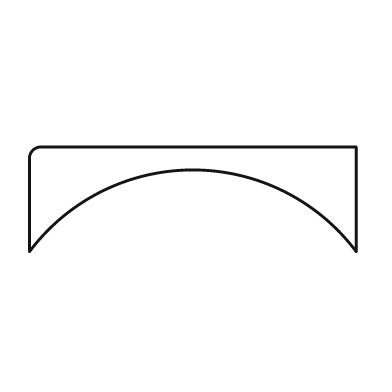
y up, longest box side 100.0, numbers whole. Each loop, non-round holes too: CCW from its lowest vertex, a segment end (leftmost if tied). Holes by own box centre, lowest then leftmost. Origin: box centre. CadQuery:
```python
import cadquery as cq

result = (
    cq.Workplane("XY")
    .moveTo(-50.0, -16.0)
    .threePointArc((0.0, 9.0), (50.0, -16.0))
    .lineTo(50.0, 16.0)
    .lineTo(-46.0, 16.0)
    .threePointArc((-49.0, 15.0), (-50.0, 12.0))
    .close()
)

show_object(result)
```